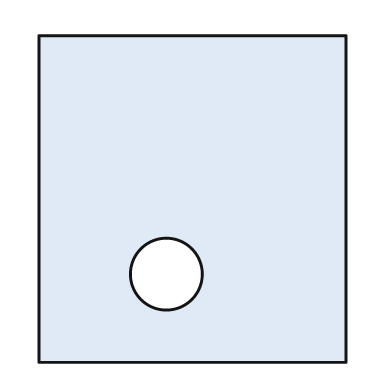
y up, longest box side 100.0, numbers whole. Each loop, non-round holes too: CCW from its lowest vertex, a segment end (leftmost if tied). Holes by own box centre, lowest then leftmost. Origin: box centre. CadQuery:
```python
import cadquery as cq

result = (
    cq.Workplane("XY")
    .moveTo(-47.0, -50.0)
    .lineTo(47.0, -50.0)
    .lineTo(47.0, 50.0)
    .lineTo(-47.0, 50.0)
    .close()
    .moveTo(-8.0, -23.0)
    .circle(11.0)
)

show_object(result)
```